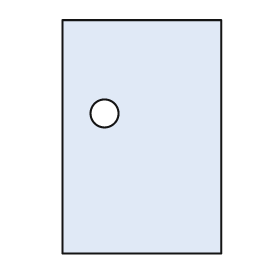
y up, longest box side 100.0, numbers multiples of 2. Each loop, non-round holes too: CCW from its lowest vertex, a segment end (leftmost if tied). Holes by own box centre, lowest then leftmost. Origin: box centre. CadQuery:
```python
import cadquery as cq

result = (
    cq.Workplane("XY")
    .moveTo(-34.0, -50.0)
    .lineTo(34.0, -50.0)
    .lineTo(34.0, 50.0)
    .lineTo(-34.0, 50.0)
    .close()
    .moveTo(-16.0, 10.0)
    .circle(6.0)
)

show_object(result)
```